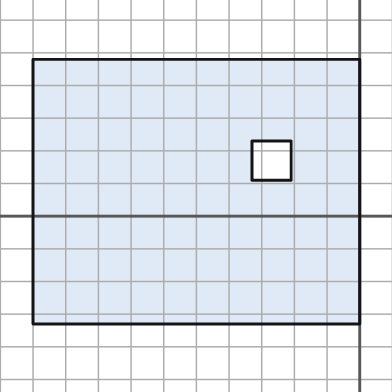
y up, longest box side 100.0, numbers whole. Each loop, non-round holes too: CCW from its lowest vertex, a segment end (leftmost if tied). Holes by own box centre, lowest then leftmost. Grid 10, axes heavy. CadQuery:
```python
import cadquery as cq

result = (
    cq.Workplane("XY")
    .moveTo(-100.0, -33.0)
    .lineTo(0.0, -33.0)
    .lineTo(0.0, 48.0)
    .lineTo(-100.0, 48.0)
    .close()
    .moveTo(-33.0, 11.0)
    .lineTo(-21.0, 11.0)
    .lineTo(-21.0, 23.0)
    .lineTo(-33.0, 23.0)
    .close()
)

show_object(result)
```